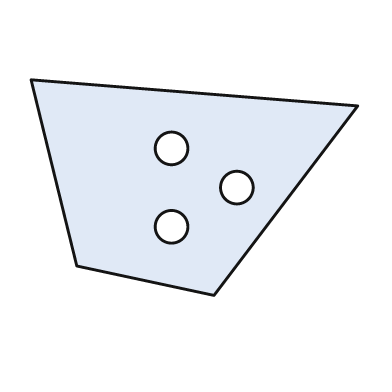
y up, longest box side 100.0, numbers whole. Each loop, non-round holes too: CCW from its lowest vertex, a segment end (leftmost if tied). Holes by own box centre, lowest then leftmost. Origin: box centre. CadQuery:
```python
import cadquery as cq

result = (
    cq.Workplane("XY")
    .moveTo(6.0, -33.0)
    .lineTo(50.0, 25.0)
    .lineTo(-50.0, 33.0)
    .lineTo(-36.0, -24.0)
    .close()
    .moveTo(-7.0, -12.0)
    .circle(5.0)
    .moveTo(13.0, 0.0)
    .circle(5.0)
    .moveTo(-7.0, 12.0)
    .circle(5.0)
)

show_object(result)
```